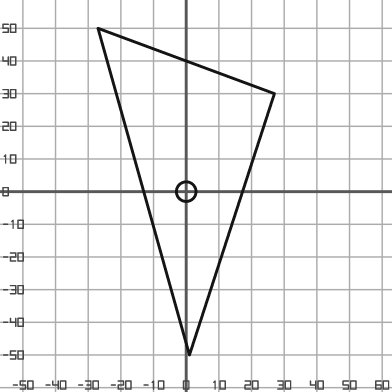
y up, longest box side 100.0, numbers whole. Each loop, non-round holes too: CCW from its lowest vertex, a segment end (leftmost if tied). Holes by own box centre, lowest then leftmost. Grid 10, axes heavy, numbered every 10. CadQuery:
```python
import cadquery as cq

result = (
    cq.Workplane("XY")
    .moveTo(1.0, -50.0)
    .lineTo(27.0, 30.0)
    .lineTo(-27.0, 50.0)
    .close()
    .moveTo(0.0, 0.0)
    .circle(3.0)
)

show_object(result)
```